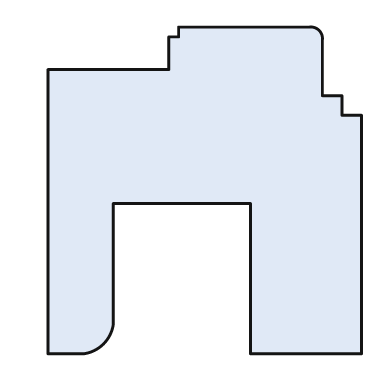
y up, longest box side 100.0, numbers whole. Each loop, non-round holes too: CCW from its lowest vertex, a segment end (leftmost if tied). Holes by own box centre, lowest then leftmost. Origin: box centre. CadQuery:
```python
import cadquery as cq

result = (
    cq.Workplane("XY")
    .moveTo(-48.0, -50.0)
    .lineTo(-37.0, -50.0)
    .threePointArc((-31.0, -47.0), (-28.0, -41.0))
    .lineTo(-28.0, -4.0)
    .lineTo(14.0, -4.0)
    .lineTo(14.0, -50.0)
    .lineTo(48.0, -50.0)
    .lineTo(48.0, 23.0)
    .lineTo(42.0, 23.0)
    .lineTo(42.0, 29.0)
    .lineTo(36.0, 29.0)
    .lineTo(36.0, 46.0)
    .threePointArc((35.0, 49.0), (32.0, 50.0))
    .lineTo(-8.0, 50.0)
    .lineTo(-8.0, 47.0)
    .lineTo(-11.0, 47.0)
    .lineTo(-11.0, 37.0)
    .lineTo(-48.0, 37.0)
    .close()
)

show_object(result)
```